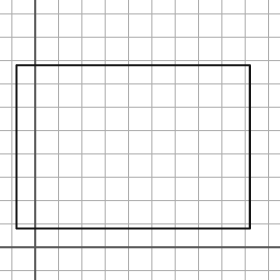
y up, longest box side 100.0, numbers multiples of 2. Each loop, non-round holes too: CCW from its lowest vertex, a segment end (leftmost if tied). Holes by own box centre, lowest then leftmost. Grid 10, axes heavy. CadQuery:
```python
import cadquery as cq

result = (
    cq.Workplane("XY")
    .moveTo(-8.0, 8.0)
    .lineTo(92.0, 8.0)
    .lineTo(92.0, 78.0)
    .lineTo(-8.0, 78.0)
    .close()
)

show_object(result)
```